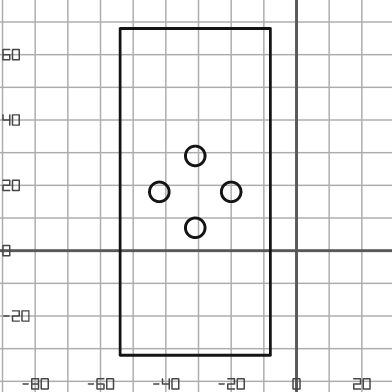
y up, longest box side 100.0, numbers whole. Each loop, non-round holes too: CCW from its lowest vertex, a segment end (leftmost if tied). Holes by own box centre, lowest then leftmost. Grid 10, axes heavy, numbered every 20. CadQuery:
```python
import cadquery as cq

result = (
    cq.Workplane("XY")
    .moveTo(-54.0, -32.0)
    .lineTo(-8.0, -32.0)
    .lineTo(-8.0, 68.0)
    .lineTo(-54.0, 68.0)
    .close()
    .moveTo(-31.0, 7.0)
    .circle(3.0)
    .moveTo(-42.0, 18.0)
    .circle(3.0)
    .moveTo(-20.0, 18.0)
    .circle(3.0)
    .moveTo(-31.0, 29.0)
    .circle(3.0)
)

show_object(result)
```